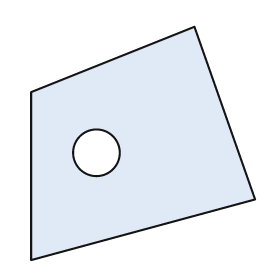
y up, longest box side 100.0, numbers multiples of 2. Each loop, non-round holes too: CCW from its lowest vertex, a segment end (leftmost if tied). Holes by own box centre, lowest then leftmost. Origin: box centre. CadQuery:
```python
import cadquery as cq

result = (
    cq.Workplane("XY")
    .moveTo(-48.0, -50.0)
    .lineTo(48.0, -24.0)
    .lineTo(22.0, 50.0)
    .lineTo(-48.0, 22.0)
    .close()
    .moveTo(-20.0, -4.0)
    .circle(10.0)
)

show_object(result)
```